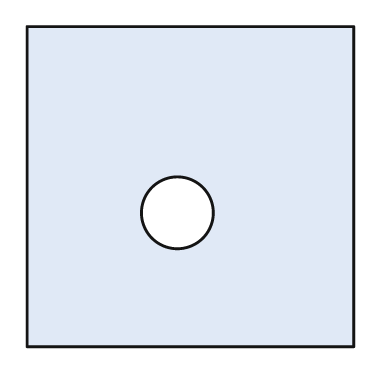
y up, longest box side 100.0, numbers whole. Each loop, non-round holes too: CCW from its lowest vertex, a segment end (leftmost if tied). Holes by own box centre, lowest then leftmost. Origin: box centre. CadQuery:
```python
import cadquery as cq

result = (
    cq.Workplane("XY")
    .moveTo(-50.0, -49.0)
    .lineTo(50.0, -49.0)
    .lineTo(50.0, 49.0)
    .lineTo(-50.0, 49.0)
    .close()
    .moveTo(-4.0, -8.0)
    .circle(11.0)
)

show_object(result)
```